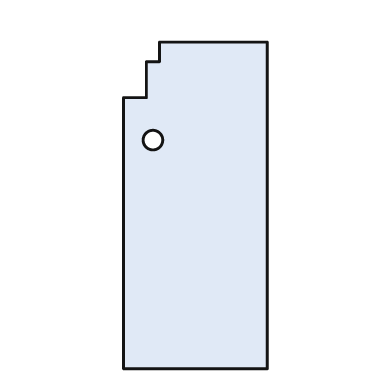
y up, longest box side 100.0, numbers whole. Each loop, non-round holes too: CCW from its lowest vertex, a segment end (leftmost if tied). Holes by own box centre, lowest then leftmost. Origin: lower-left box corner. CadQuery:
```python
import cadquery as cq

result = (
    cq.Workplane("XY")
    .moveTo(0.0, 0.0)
    .lineTo(44.0, 0.0)
    .lineTo(44.0, 100.0)
    .lineTo(11.0, 100.0)
    .lineTo(11.0, 94.0)
    .lineTo(7.0, 94.0)
    .lineTo(7.0, 83.0)
    .lineTo(0.0, 83.0)
    .close()
    .moveTo(9.0, 70.0)
    .circle(3.0)
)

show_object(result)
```